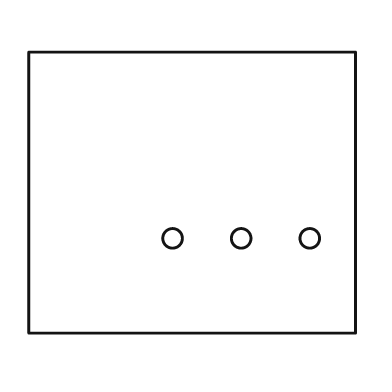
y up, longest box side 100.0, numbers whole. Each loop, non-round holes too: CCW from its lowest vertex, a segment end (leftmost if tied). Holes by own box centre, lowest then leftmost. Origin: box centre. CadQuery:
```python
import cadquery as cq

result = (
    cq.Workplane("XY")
    .moveTo(-50.0, -43.0)
    .lineTo(50.0, -43.0)
    .lineTo(50.0, 43.0)
    .lineTo(-50.0, 43.0)
    .close()
    .moveTo(-6.0, -14.0)
    .circle(3.0)
    .moveTo(15.0, -14.0)
    .circle(3.0)
    .moveTo(36.0, -14.0)
    .circle(3.0)
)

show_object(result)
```